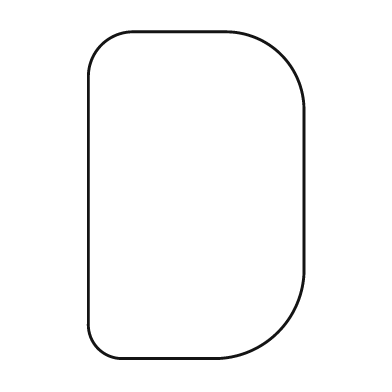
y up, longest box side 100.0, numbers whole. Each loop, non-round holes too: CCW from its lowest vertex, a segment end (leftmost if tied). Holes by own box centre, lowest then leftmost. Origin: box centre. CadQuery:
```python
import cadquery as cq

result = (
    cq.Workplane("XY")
    .moveTo(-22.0, -50.0)
    .lineTo(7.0, -50.0)
    .threePointArc((25.0, -42.0), (33.0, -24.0))
    .lineTo(33.0, 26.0)
    .threePointArc((26.0, 43.0), (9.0, 50.0))
    .lineTo(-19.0, 50.0)
    .threePointArc((-29.0, 46.0), (-33.0, 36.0))
    .lineTo(-33.0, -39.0)
    .threePointArc((-30.0, -47.0), (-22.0, -50.0))
    .close()
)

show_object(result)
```